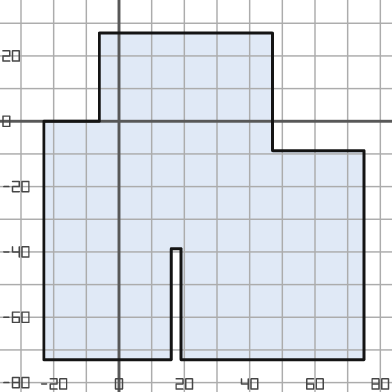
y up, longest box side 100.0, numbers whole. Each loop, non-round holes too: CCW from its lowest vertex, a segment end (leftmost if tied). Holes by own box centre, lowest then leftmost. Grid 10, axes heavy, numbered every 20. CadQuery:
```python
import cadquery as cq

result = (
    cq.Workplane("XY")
    .moveTo(-23.0, -73.0)
    .lineTo(16.0, -73.0)
    .lineTo(16.0, -39.0)
    .lineTo(19.0, -39.0)
    .lineTo(19.0, -73.0)
    .lineTo(75.0, -73.0)
    .lineTo(75.0, -9.0)
    .lineTo(47.0, -9.0)
    .lineTo(47.0, 27.0)
    .lineTo(-6.0, 27.0)
    .lineTo(-6.0, 0.0)
    .lineTo(-23.0, 0.0)
    .close()
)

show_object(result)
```